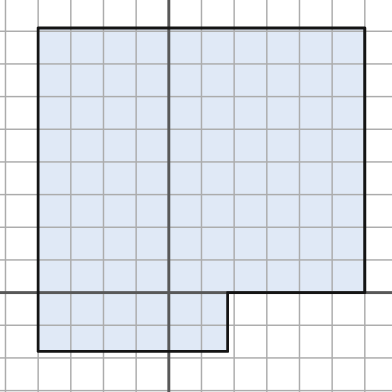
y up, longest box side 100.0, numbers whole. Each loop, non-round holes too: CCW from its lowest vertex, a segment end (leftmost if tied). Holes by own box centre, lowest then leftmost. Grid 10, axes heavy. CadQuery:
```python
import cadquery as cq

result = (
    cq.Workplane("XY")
    .moveTo(-40.0, -18.0)
    .lineTo(18.0, -18.0)
    .lineTo(18.0, 0.0)
    .lineTo(60.0, 0.0)
    .lineTo(60.0, 81.0)
    .lineTo(-40.0, 81.0)
    .close()
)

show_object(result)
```